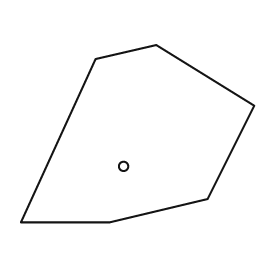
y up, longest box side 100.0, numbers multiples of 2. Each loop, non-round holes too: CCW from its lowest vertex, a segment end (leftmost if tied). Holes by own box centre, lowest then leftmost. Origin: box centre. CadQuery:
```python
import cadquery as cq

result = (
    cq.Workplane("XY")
    .moveTo(-50.0, -38.0)
    .lineTo(-12.0, -38.0)
    .lineTo(30.0, -28.0)
    .lineTo(50.0, 12.0)
    .lineTo(8.0, 38.0)
    .lineTo(-18.0, 32.0)
    .close()
    .moveTo(-6.0, -14.0)
    .circle(2.0)
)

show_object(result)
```